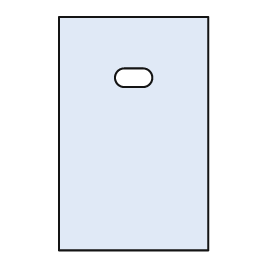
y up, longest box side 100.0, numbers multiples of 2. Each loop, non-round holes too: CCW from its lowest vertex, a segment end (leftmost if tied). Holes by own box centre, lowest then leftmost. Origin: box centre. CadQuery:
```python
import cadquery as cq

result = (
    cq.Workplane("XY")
    .moveTo(-32.0, -50.0)
    .lineTo(32.0, -50.0)
    .lineTo(32.0, 50.0)
    .lineTo(-32.0, 50.0)
    .close()
    .moveTo(-4.0, 20.0)
    .lineTo(4.0, 20.0)
    .threePointArc((8.0, 24.0), (4.0, 28.0))
    .lineTo(-4.0, 28.0)
    .threePointArc((-8.0, 24.0), (-4.0, 20.0))
    .close()
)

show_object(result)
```